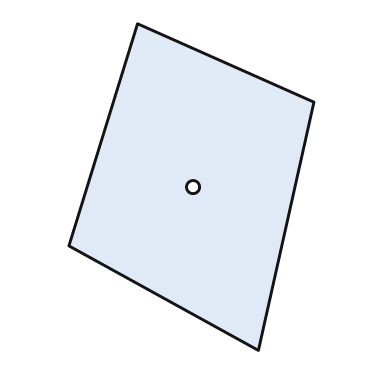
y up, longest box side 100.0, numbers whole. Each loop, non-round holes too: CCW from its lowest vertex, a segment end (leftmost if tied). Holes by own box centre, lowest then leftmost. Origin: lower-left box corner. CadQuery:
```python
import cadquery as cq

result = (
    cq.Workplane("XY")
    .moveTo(58.0, 0.0)
    .lineTo(75.0, 76.0)
    .lineTo(21.0, 100.0)
    .lineTo(0.0, 32.0)
    .close()
    .moveTo(38.0, 50.0)
    .circle(2.0)
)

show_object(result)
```